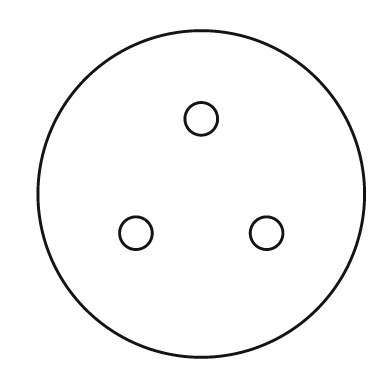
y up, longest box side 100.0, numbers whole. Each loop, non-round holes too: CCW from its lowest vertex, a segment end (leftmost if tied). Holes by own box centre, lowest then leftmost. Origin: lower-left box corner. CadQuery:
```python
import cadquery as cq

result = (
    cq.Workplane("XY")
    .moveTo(50.0, 50.0)
    .circle(50.0)
    .moveTo(30.0, 38.0)
    .circle(5.0)
    .moveTo(70.0, 38.0)
    .circle(5.0)
    .moveTo(50.0, 73.0)
    .circle(5.0)
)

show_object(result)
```